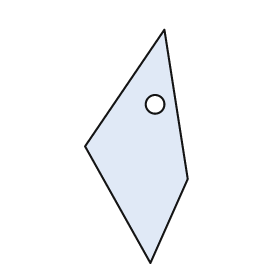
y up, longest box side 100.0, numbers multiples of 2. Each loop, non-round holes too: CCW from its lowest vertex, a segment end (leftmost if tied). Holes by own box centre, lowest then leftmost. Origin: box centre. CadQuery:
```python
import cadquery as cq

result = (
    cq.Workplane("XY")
    .moveTo(6.0, -50.0)
    .lineTo(22.0, -14.0)
    .lineTo(12.0, 50.0)
    .lineTo(-22.0, 0.0)
    .close()
    .moveTo(8.0, 18.0)
    .circle(4.0)
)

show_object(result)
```